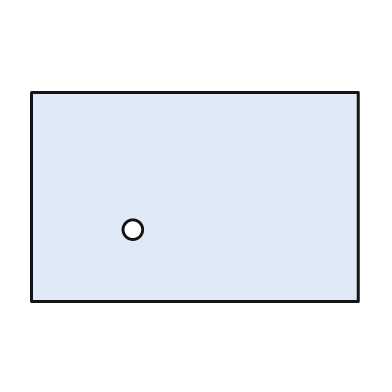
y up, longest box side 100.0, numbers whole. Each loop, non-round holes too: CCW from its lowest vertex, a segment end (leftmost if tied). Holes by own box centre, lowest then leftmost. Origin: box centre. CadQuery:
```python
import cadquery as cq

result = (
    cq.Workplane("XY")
    .moveTo(-50.0, -32.0)
    .lineTo(50.0, -32.0)
    .lineTo(50.0, 32.0)
    .lineTo(-50.0, 32.0)
    .close()
    .moveTo(-19.0, -10.0)
    .circle(3.0)
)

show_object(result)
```